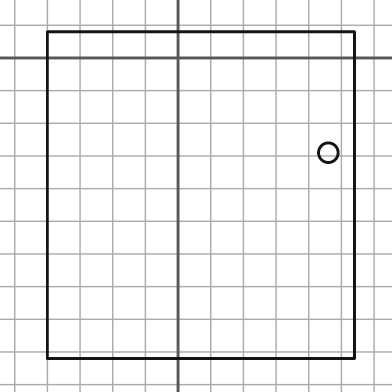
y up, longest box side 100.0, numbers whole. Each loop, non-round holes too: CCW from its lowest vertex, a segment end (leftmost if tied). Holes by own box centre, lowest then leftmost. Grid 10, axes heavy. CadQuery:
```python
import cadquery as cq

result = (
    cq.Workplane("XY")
    .moveTo(-40.0, -92.0)
    .lineTo(54.0, -92.0)
    .lineTo(54.0, 8.0)
    .lineTo(-40.0, 8.0)
    .close()
    .moveTo(46.0, -29.0)
    .circle(3.0)
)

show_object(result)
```